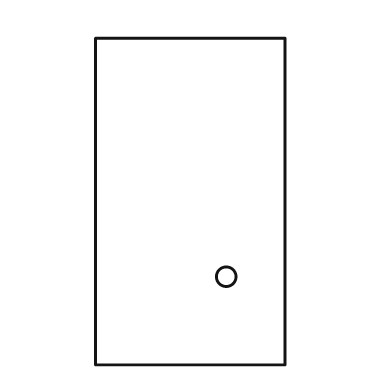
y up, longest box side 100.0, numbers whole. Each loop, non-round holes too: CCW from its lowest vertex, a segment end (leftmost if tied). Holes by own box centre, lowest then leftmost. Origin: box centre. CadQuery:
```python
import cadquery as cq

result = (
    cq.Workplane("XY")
    .moveTo(-29.0, -50.0)
    .lineTo(29.0, -50.0)
    .lineTo(29.0, 50.0)
    .lineTo(-29.0, 50.0)
    .close()
    .moveTo(11.0, -23.0)
    .circle(3.0)
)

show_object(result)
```